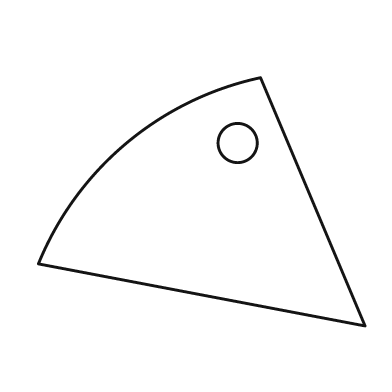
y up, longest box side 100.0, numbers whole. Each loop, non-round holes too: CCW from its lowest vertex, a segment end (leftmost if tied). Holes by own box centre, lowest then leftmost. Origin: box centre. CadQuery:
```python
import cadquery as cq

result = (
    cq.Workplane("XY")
    .moveTo(50.0, -38.0)
    .lineTo(18.0, 38.0)
    .threePointArc((-23.0, 18.0), (-50.0, -19.0))
    .close()
    .moveTo(11.0, 18.0)
    .circle(6.0)
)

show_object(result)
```